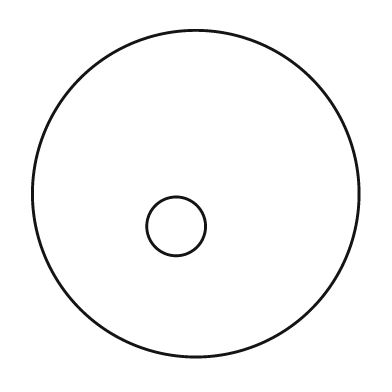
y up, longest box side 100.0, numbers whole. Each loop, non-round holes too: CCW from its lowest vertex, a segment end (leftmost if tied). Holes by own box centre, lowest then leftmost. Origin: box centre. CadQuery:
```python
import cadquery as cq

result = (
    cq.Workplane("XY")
    .moveTo(0.0, 0.0)
    .circle(50.0)
    .moveTo(-6.0, -10.0)
    .circle(9.0)
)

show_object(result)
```